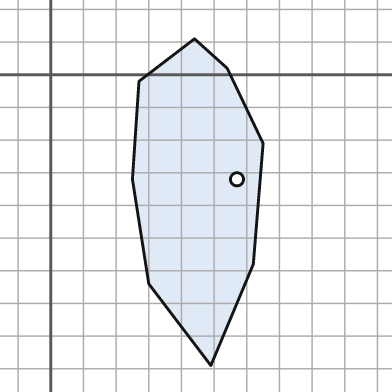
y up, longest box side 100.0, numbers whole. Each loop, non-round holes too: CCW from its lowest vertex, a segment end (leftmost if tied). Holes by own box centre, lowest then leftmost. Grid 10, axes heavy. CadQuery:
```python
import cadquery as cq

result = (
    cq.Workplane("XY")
    .moveTo(49.0, -89.0)
    .lineTo(62.0, -58.0)
    .lineTo(65.0, -21.0)
    .lineTo(54.0, 2.0)
    .lineTo(44.0, 11.0)
    .lineTo(27.0, -2.0)
    .lineTo(25.0, -32.0)
    .lineTo(30.0, -64.0)
    .close()
    .moveTo(57.0, -32.0)
    .circle(2.0)
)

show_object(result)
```